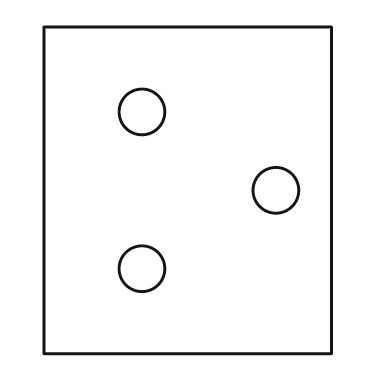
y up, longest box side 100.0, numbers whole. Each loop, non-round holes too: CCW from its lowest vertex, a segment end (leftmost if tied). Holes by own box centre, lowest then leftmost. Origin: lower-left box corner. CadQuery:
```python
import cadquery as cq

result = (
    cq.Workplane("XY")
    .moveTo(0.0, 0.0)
    .lineTo(88.0, 0.0)
    .lineTo(88.0, 100.0)
    .lineTo(0.0, 100.0)
    .close()
    .moveTo(30.0, 26.0)
    .circle(7.0)
    .moveTo(71.0, 50.0)
    .circle(7.0)
    .moveTo(30.0, 74.0)
    .circle(7.0)
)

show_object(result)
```